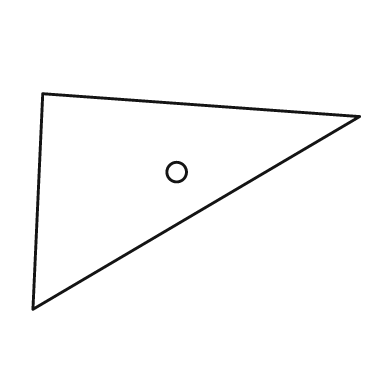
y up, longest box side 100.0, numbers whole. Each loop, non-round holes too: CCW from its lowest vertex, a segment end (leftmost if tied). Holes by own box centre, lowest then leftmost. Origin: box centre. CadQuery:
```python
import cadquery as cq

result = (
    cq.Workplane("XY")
    .moveTo(-50.0, -33.0)
    .lineTo(50.0, 26.0)
    .lineTo(-47.0, 33.0)
    .close()
    .moveTo(-6.0, 9.0)
    .circle(3.0)
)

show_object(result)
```